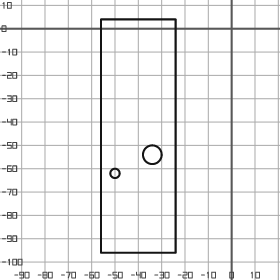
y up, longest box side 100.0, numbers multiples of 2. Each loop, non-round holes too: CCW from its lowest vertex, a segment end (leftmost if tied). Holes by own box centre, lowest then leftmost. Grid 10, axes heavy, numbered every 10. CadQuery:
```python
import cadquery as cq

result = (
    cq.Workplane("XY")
    .moveTo(-56.0, -96.0)
    .lineTo(-24.0, -96.0)
    .lineTo(-24.0, 4.0)
    .lineTo(-56.0, 4.0)
    .close()
    .moveTo(-50.0, -62.0)
    .circle(2.0)
    .moveTo(-34.0, -54.0)
    .circle(4.0)
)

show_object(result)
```